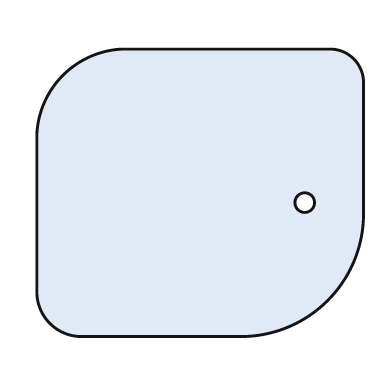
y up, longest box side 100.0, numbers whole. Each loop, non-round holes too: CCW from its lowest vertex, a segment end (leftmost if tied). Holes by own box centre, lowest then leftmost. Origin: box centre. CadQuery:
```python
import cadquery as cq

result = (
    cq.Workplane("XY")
    .moveTo(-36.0, -44.0)
    .lineTo(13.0, -44.0)
    .threePointArc((39.0, -33.0), (50.0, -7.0))
    .lineTo(50.0, 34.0)
    .threePointArc((47.0, 41.0), (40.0, 44.0))
    .lineTo(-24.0, 44.0)
    .threePointArc((-42.0, 36.0), (-50.0, 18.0))
    .lineTo(-50.0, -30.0)
    .threePointArc((-46.0, -40.0), (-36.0, -44.0))
    .close()
    .moveTo(32.0, -3.0)
    .circle(3.0)
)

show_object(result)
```